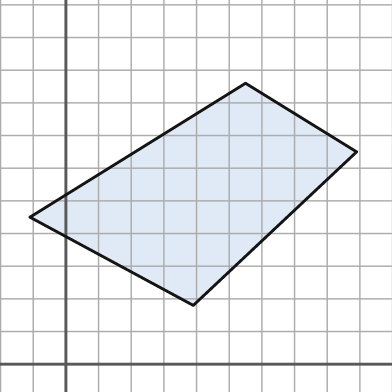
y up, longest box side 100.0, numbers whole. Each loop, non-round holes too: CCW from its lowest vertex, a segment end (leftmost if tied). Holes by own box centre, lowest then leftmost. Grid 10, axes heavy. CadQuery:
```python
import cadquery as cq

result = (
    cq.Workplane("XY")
    .moveTo(39.0, 18.0)
    .lineTo(89.0, 65.0)
    .lineTo(55.0, 86.0)
    .lineTo(-11.0, 45.0)
    .close()
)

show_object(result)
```